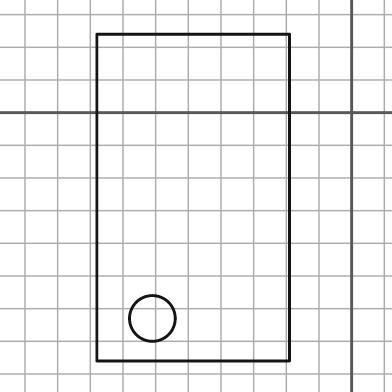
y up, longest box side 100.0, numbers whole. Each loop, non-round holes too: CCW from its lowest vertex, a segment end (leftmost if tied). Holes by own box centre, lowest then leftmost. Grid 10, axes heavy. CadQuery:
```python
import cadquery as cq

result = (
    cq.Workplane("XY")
    .moveTo(-78.0, -76.0)
    .lineTo(-19.0, -76.0)
    .lineTo(-19.0, 24.0)
    .lineTo(-78.0, 24.0)
    .close()
    .moveTo(-61.0, -63.0)
    .circle(7.0)
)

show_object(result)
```